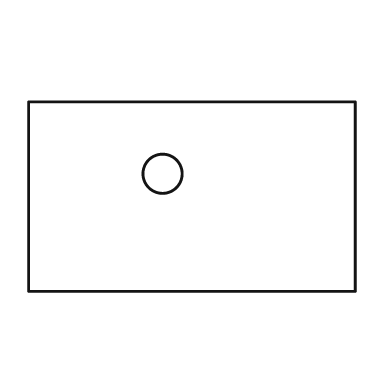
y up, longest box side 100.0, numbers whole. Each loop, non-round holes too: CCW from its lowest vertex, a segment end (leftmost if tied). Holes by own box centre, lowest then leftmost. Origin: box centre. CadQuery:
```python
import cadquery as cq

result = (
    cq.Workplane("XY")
    .moveTo(-50.0, -29.0)
    .lineTo(50.0, -29.0)
    .lineTo(50.0, 29.0)
    .lineTo(-50.0, 29.0)
    .close()
    .moveTo(-9.0, 7.0)
    .circle(6.0)
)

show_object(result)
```